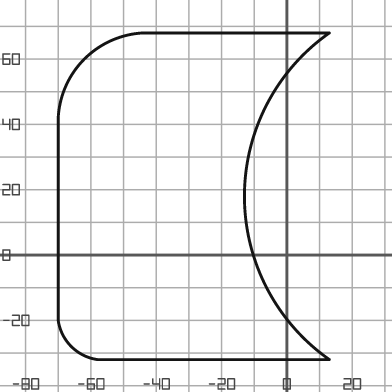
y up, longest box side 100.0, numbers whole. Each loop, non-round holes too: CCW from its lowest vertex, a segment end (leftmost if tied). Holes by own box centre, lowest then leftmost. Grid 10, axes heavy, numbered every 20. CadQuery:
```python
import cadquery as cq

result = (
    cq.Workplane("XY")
    .moveTo(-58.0, -32.0)
    .lineTo(13.0, -32.0)
    .threePointArc((-13.0, 18.0), (13.0, 68.0))
    .lineTo(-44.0, 68.0)
    .threePointArc((-62.0, 60.0), (-70.0, 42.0))
    .lineTo(-70.0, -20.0)
    .threePointArc((-66.0, -28.0), (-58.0, -32.0))
    .close()
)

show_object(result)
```